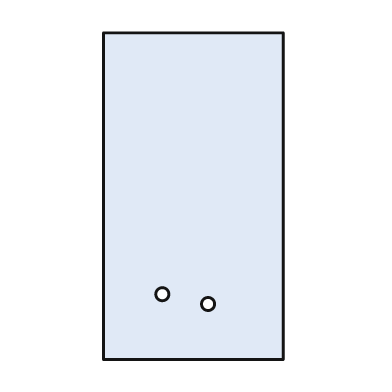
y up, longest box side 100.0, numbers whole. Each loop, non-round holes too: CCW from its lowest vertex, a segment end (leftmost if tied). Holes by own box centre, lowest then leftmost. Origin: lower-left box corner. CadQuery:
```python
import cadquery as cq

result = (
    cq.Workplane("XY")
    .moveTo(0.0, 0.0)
    .lineTo(55.0, 0.0)
    .lineTo(55.0, 100.0)
    .lineTo(0.0, 100.0)
    .close()
    .moveTo(32.0, 17.0)
    .circle(2.0)
    .moveTo(18.0, 20.0)
    .circle(2.0)
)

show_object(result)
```